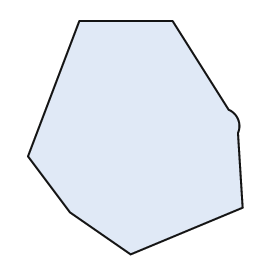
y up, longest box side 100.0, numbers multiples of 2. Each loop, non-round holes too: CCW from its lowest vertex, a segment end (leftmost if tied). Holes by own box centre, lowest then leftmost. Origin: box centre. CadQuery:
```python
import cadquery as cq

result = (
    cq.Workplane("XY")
    .moveTo(-2.0, -50.0)
    .lineTo(46.0, -30.0)
    .lineTo(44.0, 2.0)
    .threePointArc((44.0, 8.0), (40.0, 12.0))
    .lineTo(16.0, 50.0)
    .lineTo(-24.0, 50.0)
    .lineTo(-46.0, -8.0)
    .lineTo(-28.0, -32.0)
    .close()
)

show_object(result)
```